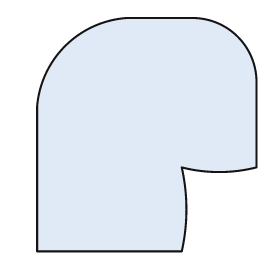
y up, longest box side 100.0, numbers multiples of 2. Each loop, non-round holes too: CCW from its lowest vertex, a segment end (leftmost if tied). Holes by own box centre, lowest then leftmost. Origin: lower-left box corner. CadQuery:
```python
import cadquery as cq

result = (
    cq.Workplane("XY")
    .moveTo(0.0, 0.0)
    .lineTo(62.0, 0.0)
    .threePointArc((64.0, 18.0), (62.0, 36.0))
    .threePointArc((78.0, 34.0), (94.0, 36.0))
    .lineTo(94.0, 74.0)
    .threePointArc((86.0, 92.0), (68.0, 100.0))
    .lineTo(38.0, 100.0)
    .threePointArc((12.0, 88.0), (0.0, 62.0))
    .close()
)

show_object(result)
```